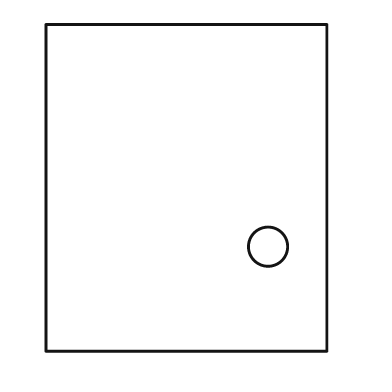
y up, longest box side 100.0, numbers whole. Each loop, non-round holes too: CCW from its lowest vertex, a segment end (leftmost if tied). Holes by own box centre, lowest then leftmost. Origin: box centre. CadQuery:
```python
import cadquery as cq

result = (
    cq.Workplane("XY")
    .moveTo(-43.0, -50.0)
    .lineTo(43.0, -50.0)
    .lineTo(43.0, 50.0)
    .lineTo(-43.0, 50.0)
    .close()
    .moveTo(25.0, -18.0)
    .circle(6.0)
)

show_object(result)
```